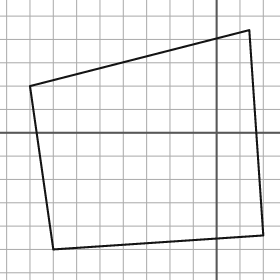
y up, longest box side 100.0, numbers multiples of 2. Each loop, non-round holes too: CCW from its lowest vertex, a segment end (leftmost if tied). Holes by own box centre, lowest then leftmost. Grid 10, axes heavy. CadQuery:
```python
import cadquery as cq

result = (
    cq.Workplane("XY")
    .moveTo(-70.0, -50.0)
    .lineTo(20.0, -44.0)
    .lineTo(14.0, 44.0)
    .lineTo(-80.0, 20.0)
    .close()
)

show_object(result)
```